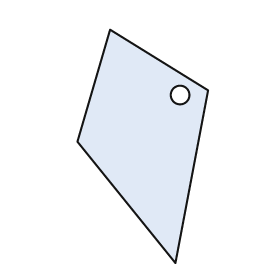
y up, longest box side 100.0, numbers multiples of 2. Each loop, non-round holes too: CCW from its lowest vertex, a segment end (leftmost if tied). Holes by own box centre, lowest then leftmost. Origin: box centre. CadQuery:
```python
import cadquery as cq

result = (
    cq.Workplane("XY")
    .moveTo(14.0, -50.0)
    .lineTo(28.0, 24.0)
    .lineTo(-14.0, 50.0)
    .lineTo(-28.0, 2.0)
    .close()
    .moveTo(16.0, 22.0)
    .circle(4.0)
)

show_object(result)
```